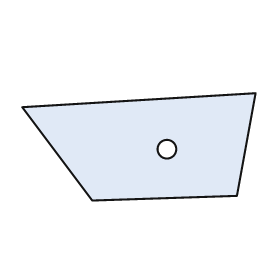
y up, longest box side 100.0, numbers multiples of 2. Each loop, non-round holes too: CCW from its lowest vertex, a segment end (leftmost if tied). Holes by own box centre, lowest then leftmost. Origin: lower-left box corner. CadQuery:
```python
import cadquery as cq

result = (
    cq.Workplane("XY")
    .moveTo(30.0, 0.0)
    .lineTo(92.0, 2.0)
    .lineTo(100.0, 46.0)
    .lineTo(0.0, 40.0)
    .close()
    .moveTo(62.0, 22.0)
    .circle(4.0)
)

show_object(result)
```